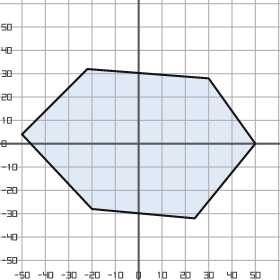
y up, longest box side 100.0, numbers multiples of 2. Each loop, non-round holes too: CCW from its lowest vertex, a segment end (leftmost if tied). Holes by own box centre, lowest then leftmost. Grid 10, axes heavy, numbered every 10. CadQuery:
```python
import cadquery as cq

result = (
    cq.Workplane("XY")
    .moveTo(24.0, -32.0)
    .lineTo(50.0, 0.0)
    .lineTo(30.0, 28.0)
    .lineTo(-22.0, 32.0)
    .lineTo(-50.0, 4.0)
    .lineTo(-20.0, -28.0)
    .close()
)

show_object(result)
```